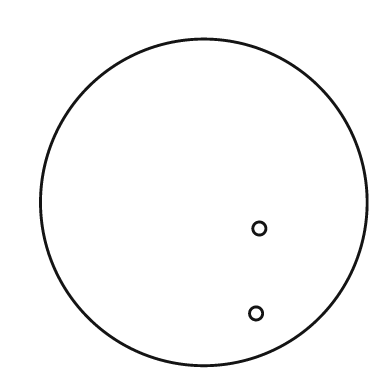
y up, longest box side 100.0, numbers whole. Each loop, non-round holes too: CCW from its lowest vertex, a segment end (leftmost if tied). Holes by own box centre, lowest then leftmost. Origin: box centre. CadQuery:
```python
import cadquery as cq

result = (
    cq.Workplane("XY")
    .moveTo(0.0, 0.0)
    .circle(50.0)
    .moveTo(16.0, -34.0)
    .circle(2.0)
    .moveTo(17.0, -8.0)
    .circle(2.0)
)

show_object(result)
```